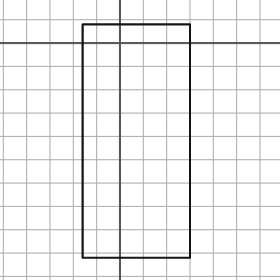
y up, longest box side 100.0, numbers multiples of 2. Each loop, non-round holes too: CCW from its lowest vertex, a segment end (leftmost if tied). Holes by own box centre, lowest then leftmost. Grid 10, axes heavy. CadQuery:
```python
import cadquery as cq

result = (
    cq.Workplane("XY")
    .moveTo(-16.0, -92.0)
    .lineTo(30.0, -92.0)
    .lineTo(30.0, 8.0)
    .lineTo(-16.0, 8.0)
    .close()
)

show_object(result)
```